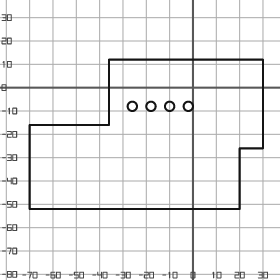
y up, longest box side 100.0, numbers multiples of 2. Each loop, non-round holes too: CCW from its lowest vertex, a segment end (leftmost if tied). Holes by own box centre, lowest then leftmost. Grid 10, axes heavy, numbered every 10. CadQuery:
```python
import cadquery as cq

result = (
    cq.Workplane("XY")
    .moveTo(-70.0, -52.0)
    .lineTo(20.0, -52.0)
    .lineTo(20.0, -26.0)
    .lineTo(30.0, -26.0)
    .lineTo(30.0, 12.0)
    .lineTo(-36.0, 12.0)
    .lineTo(-36.0, -16.0)
    .lineTo(-70.0, -16.0)
    .close()
    .moveTo(-26.0, -8.0)
    .circle(2.0)
    .moveTo(-18.0, -8.0)
    .circle(2.0)
    .moveTo(-10.0, -8.0)
    .circle(2.0)
    .moveTo(-2.0, -8.0)
    .circle(2.0)
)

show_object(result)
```